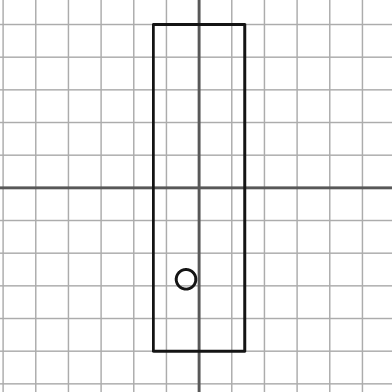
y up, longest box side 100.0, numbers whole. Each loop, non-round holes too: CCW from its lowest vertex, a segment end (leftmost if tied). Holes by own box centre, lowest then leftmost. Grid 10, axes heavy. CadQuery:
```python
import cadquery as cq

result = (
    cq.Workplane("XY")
    .moveTo(-14.0, -50.0)
    .lineTo(14.0, -50.0)
    .lineTo(14.0, 50.0)
    .lineTo(-14.0, 50.0)
    .close()
    .moveTo(-4.0, -28.0)
    .circle(3.0)
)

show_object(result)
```